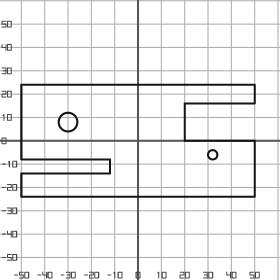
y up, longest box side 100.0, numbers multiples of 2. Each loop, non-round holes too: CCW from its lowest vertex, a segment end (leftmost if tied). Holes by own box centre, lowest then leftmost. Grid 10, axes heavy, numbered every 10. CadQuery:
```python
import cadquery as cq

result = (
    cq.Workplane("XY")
    .moveTo(-50.0, -24.0)
    .lineTo(50.0, -24.0)
    .lineTo(50.0, 0.0)
    .lineTo(20.0, 0.0)
    .lineTo(20.0, 16.0)
    .lineTo(50.0, 16.0)
    .lineTo(50.0, 24.0)
    .lineTo(-50.0, 24.0)
    .lineTo(-50.0, -8.0)
    .lineTo(-12.0, -8.0)
    .lineTo(-12.0, -14.0)
    .lineTo(-50.0, -14.0)
    .close()
    .moveTo(32.0, -6.0)
    .circle(2.0)
    .moveTo(-30.0, 8.0)
    .circle(4.0)
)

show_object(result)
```